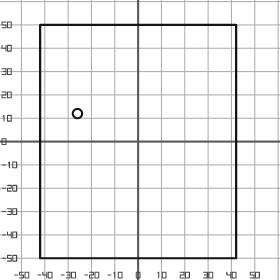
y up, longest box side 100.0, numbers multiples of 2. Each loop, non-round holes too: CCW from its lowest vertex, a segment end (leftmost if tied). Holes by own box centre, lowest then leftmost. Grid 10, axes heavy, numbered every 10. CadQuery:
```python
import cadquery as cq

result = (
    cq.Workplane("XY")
    .moveTo(-42.0, -50.0)
    .lineTo(42.0, -50.0)
    .lineTo(42.0, 50.0)
    .lineTo(-42.0, 50.0)
    .close()
    .moveTo(-26.0, 12.0)
    .circle(2.0)
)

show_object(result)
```